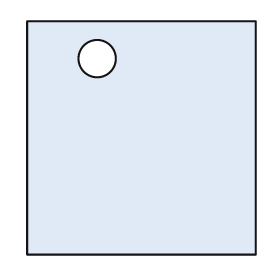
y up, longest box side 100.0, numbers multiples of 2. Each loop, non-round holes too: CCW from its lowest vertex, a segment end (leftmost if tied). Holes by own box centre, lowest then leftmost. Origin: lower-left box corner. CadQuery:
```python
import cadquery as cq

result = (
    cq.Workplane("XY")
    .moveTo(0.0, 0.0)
    .lineTo(98.0, 0.0)
    .lineTo(98.0, 100.0)
    .lineTo(0.0, 100.0)
    .close()
    .moveTo(30.0, 84.0)
    .circle(8.0)
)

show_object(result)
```